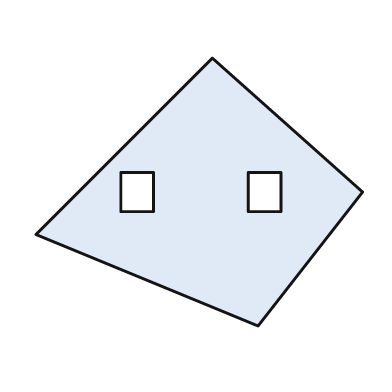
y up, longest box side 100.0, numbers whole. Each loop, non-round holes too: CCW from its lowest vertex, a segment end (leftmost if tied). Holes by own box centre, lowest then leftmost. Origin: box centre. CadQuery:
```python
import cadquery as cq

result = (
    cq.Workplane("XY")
    .moveTo(18.0, -41.0)
    .lineTo(50.0, 0.0)
    .lineTo(4.0, 41.0)
    .lineTo(-50.0, -13.0)
    .close()
    .moveTo(-24.0, -6.0)
    .lineTo(-14.0, -6.0)
    .lineTo(-14.0, 6.0)
    .lineTo(-24.0, 6.0)
    .close()
    .moveTo(15.0, -6.0)
    .lineTo(25.0, -6.0)
    .lineTo(25.0, 6.0)
    .lineTo(15.0, 6.0)
    .close()
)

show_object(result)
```